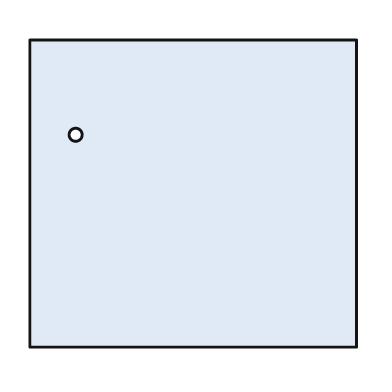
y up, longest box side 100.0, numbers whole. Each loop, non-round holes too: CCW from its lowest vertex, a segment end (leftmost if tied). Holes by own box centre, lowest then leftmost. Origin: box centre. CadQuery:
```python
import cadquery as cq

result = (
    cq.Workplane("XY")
    .moveTo(-50.0, -47.0)
    .lineTo(50.0, -47.0)
    .lineTo(50.0, 47.0)
    .lineTo(-50.0, 47.0)
    .close()
    .moveTo(-36.0, 18.0)
    .circle(2.0)
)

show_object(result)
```